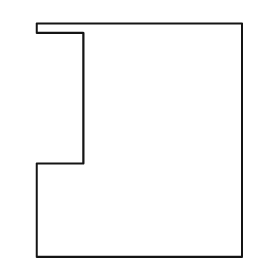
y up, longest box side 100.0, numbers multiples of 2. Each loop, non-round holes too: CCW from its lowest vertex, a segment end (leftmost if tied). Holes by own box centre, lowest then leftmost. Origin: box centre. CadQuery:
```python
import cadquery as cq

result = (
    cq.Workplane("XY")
    .moveTo(-44.0, -50.0)
    .lineTo(44.0, -50.0)
    .lineTo(44.0, 50.0)
    .lineTo(-44.0, 50.0)
    .lineTo(-44.0, 46.0)
    .lineTo(-24.0, 46.0)
    .lineTo(-24.0, -10.0)
    .lineTo(-44.0, -10.0)
    .close()
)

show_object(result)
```